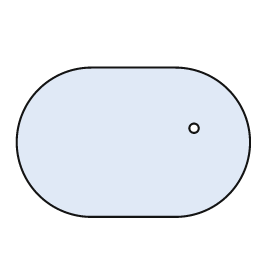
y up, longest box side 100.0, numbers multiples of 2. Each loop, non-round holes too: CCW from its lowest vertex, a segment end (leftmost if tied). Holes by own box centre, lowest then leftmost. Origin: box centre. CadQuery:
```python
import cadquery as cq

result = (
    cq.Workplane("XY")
    .moveTo(-18.0, -32.0)
    .lineTo(18.0, -32.0)
    .threePointArc((50.0, 0.0), (18.0, 32.0))
    .lineTo(-18.0, 32.0)
    .threePointArc((-50.0, 0.0), (-18.0, -32.0))
    .close()
    .moveTo(26.0, 6.0)
    .circle(2.0)
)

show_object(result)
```